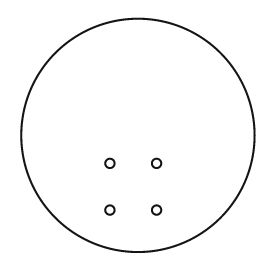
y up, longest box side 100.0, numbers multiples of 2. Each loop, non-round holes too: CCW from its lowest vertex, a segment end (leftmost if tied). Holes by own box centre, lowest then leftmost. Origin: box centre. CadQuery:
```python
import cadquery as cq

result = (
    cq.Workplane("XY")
    .moveTo(0.0, 0.0)
    .circle(50.0)
    .moveTo(-12.0, -32.0)
    .circle(2.0)
    .moveTo(8.0, -32.0)
    .circle(2.0)
    .moveTo(-12.0, -12.0)
    .circle(2.0)
    .moveTo(8.0, -12.0)
    .circle(2.0)
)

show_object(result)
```